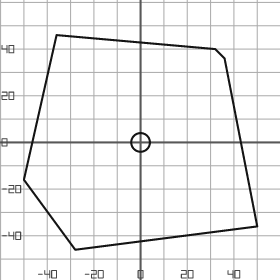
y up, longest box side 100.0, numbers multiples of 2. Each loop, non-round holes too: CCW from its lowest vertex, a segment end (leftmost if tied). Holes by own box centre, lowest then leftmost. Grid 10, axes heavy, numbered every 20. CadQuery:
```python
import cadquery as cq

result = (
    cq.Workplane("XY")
    .moveTo(-28.0, -46.0)
    .lineTo(50.0, -36.0)
    .lineTo(36.0, 36.0)
    .lineTo(32.0, 40.0)
    .lineTo(-36.0, 46.0)
    .lineTo(-50.0, -16.0)
    .close()
    .moveTo(0.0, 0.0)
    .circle(4.0)
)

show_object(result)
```